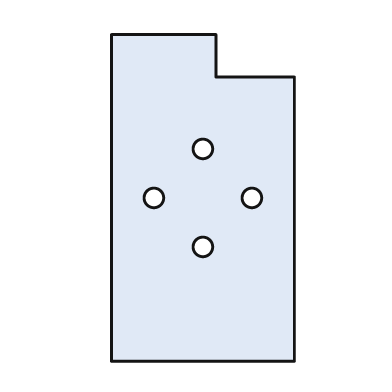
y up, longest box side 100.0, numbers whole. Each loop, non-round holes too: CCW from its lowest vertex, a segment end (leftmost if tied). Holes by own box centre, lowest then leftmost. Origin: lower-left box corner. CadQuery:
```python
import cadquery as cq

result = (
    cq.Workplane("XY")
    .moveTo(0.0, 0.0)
    .lineTo(56.0, 0.0)
    .lineTo(56.0, 87.0)
    .lineTo(32.0, 87.0)
    .lineTo(32.0, 100.0)
    .lineTo(0.0, 100.0)
    .close()
    .moveTo(28.0, 35.0)
    .circle(3.0)
    .moveTo(13.0, 50.0)
    .circle(3.0)
    .moveTo(43.0, 50.0)
    .circle(3.0)
    .moveTo(28.0, 65.0)
    .circle(3.0)
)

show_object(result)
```